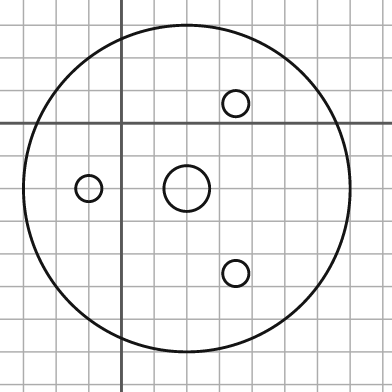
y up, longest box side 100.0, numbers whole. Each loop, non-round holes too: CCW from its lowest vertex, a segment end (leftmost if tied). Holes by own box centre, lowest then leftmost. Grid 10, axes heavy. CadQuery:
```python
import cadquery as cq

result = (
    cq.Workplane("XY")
    .moveTo(20.0, -20.0)
    .circle(50.0)
    .moveTo(35.0, -46.0)
    .circle(4.0)
    .moveTo(-10.0, -20.0)
    .circle(4.0)
    .moveTo(20.0, -20.0)
    .circle(7.0)
    .moveTo(35.0, 6.0)
    .circle(4.0)
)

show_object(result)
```